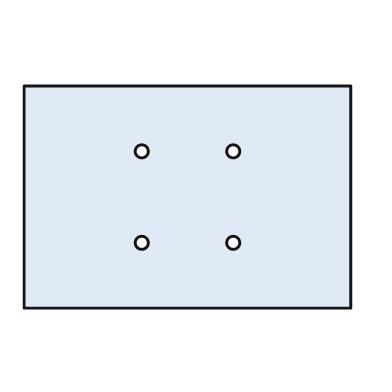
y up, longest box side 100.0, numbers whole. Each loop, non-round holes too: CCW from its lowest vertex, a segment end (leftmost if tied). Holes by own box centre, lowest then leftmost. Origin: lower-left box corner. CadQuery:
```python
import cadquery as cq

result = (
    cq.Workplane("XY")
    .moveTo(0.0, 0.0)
    .lineTo(100.0, 0.0)
    .lineTo(100.0, 68.0)
    .lineTo(0.0, 68.0)
    .close()
    .moveTo(36.0, 20.0)
    .circle(2.0)
    .moveTo(64.0, 20.0)
    .circle(2.0)
    .moveTo(36.0, 48.0)
    .circle(2.0)
    .moveTo(64.0, 48.0)
    .circle(2.0)
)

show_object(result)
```